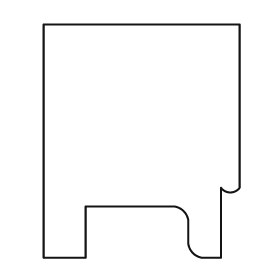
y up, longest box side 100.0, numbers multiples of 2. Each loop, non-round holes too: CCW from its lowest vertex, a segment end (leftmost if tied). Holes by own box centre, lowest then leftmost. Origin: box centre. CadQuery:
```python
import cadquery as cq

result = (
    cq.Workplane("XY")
    .moveTo(-42.0, -50.0)
    .lineTo(-24.0, -50.0)
    .lineTo(-24.0, -28.0)
    .lineTo(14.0, -28.0)
    .threePointArc((18.0, -30.0), (20.0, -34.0))
    .lineTo(20.0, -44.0)
    .threePointArc((22.0, -48.0), (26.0, -50.0))
    .lineTo(34.0, -50.0)
    .lineTo(34.0, -20.0)
    .threePointArc((38.0, -22.0), (42.0, -20.0))
    .lineTo(42.0, 50.0)
    .lineTo(-42.0, 50.0)
    .close()
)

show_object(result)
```